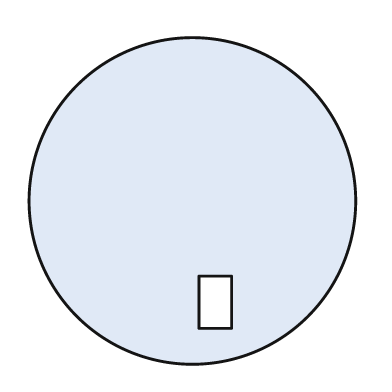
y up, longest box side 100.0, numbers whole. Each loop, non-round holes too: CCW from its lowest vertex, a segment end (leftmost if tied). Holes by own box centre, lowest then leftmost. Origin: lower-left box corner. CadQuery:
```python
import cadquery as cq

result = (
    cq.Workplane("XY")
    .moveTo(50.0, 50.0)
    .circle(50.0)
    .moveTo(52.0, 11.0)
    .lineTo(62.0, 11.0)
    .lineTo(62.0, 27.0)
    .lineTo(52.0, 27.0)
    .close()
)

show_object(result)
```